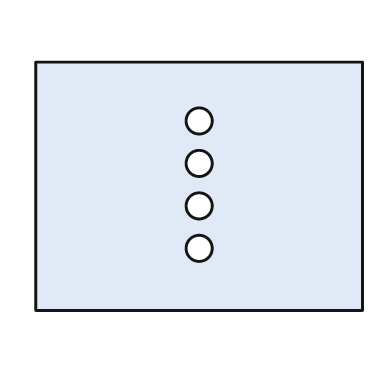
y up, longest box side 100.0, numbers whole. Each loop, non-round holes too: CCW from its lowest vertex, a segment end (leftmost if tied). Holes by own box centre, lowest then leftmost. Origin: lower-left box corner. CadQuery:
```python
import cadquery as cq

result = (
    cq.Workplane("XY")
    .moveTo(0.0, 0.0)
    .lineTo(100.0, 0.0)
    .lineTo(100.0, 76.0)
    .lineTo(0.0, 76.0)
    .close()
    .moveTo(50.0, 19.0)
    .circle(4.0)
    .moveTo(50.0, 32.0)
    .circle(4.0)
    .moveTo(50.0, 45.0)
    .circle(4.0)
    .moveTo(50.0, 58.0)
    .circle(4.0)
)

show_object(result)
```